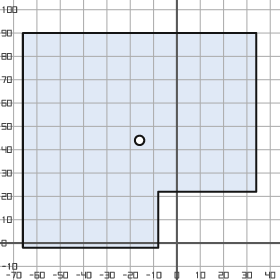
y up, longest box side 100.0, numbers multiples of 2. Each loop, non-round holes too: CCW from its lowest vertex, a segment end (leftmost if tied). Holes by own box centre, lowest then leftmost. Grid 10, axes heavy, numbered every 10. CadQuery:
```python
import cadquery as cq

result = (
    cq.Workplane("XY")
    .moveTo(-66.0, -2.0)
    .lineTo(-8.0, -2.0)
    .lineTo(-8.0, 22.0)
    .lineTo(34.0, 22.0)
    .lineTo(34.0, 90.0)
    .lineTo(-66.0, 90.0)
    .close()
    .moveTo(-16.0, 44.0)
    .circle(2.0)
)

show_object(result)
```